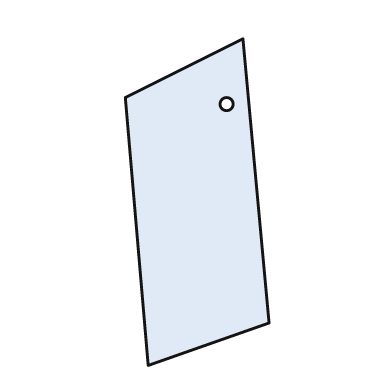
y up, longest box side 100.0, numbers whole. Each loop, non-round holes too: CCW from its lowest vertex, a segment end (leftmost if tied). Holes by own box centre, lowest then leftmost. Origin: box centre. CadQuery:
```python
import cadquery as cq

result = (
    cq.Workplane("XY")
    .moveTo(-15.0, -50.0)
    .lineTo(22.0, -37.0)
    .lineTo(14.0, 50.0)
    .lineTo(-22.0, 32.0)
    .close()
    .moveTo(9.0, 30.0)
    .circle(2.0)
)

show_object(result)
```